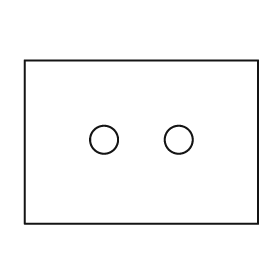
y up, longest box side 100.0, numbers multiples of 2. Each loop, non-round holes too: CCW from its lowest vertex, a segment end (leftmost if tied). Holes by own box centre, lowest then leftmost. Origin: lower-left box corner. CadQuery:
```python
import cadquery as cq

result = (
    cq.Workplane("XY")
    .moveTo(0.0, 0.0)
    .lineTo(100.0, 0.0)
    .lineTo(100.0, 70.0)
    .lineTo(0.0, 70.0)
    .close()
    .moveTo(34.0, 36.0)
    .circle(6.0)
    .moveTo(66.0, 36.0)
    .circle(6.0)
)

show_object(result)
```